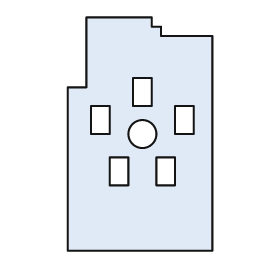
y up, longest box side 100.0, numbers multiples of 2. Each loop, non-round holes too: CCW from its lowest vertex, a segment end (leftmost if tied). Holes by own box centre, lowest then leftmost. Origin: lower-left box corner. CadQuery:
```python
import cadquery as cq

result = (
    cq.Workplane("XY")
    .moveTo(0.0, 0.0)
    .lineTo(62.0, 0.0)
    .lineTo(62.0, 92.0)
    .lineTo(40.0, 92.0)
    .lineTo(40.0, 96.0)
    .lineTo(36.0, 96.0)
    .lineTo(36.0, 100.0)
    .lineTo(8.0, 100.0)
    .lineTo(8.0, 70.0)
    .lineTo(0.0, 70.0)
    .close()
    .moveTo(18.0, 28.0)
    .lineTo(26.0, 28.0)
    .lineTo(26.0, 40.0)
    .lineTo(18.0, 40.0)
    .close()
    .moveTo(38.0, 28.0)
    .lineTo(46.0, 28.0)
    .lineTo(46.0, 40.0)
    .lineTo(38.0, 40.0)
    .close()
    .moveTo(32.0, 50.0)
    .circle(6.0)
    .moveTo(10.0, 50.0)
    .lineTo(18.0, 50.0)
    .lineTo(18.0, 62.0)
    .lineTo(10.0, 62.0)
    .close()
    .moveTo(46.0, 50.0)
    .lineTo(54.0, 50.0)
    .lineTo(54.0, 62.0)
    .lineTo(46.0, 62.0)
    .close()
    .moveTo(28.0, 62.0)
    .lineTo(36.0, 62.0)
    .lineTo(36.0, 74.0)
    .lineTo(28.0, 74.0)
    .close()
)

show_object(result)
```